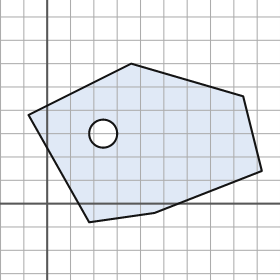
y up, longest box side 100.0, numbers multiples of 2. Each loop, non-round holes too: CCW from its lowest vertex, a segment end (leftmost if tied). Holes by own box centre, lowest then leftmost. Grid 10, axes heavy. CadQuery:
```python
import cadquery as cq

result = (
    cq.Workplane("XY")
    .moveTo(18.0, -8.0)
    .lineTo(46.0, -4.0)
    .lineTo(92.0, 14.0)
    .lineTo(84.0, 46.0)
    .lineTo(36.0, 60.0)
    .lineTo(-8.0, 38.0)
    .close()
    .moveTo(24.0, 30.0)
    .circle(6.0)
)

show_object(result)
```